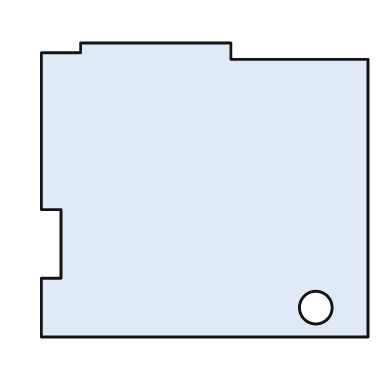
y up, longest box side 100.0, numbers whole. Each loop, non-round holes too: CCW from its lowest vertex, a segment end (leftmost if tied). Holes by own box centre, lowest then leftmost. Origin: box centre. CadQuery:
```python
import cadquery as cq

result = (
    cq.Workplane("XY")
    .moveTo(-50.0, -45.0)
    .lineTo(50.0, -45.0)
    .lineTo(50.0, 40.0)
    .lineTo(8.0, 40.0)
    .lineTo(8.0, 45.0)
    .lineTo(-38.0, 45.0)
    .lineTo(-38.0, 42.0)
    .lineTo(-50.0, 42.0)
    .lineTo(-50.0, -6.0)
    .lineTo(-44.0, -6.0)
    .lineTo(-44.0, -27.0)
    .lineTo(-50.0, -27.0)
    .close()
    .moveTo(34.0, -36.0)
    .circle(5.0)
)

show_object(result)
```